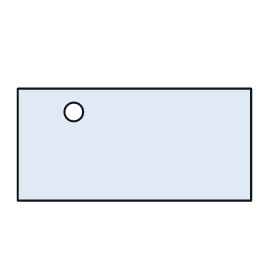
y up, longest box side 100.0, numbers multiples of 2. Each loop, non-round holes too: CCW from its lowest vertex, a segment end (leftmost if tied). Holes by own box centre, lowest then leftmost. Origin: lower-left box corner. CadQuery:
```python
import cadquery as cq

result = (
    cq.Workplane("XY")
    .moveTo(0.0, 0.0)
    .lineTo(100.0, 0.0)
    .lineTo(100.0, 48.0)
    .lineTo(0.0, 48.0)
    .close()
    .moveTo(24.0, 38.0)
    .circle(4.0)
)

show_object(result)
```